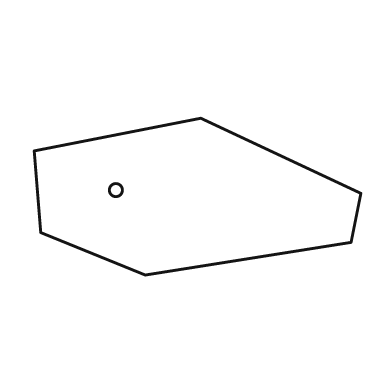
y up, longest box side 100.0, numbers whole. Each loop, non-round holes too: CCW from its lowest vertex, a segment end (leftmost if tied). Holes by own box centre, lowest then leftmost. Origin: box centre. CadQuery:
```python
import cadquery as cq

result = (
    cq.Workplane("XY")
    .moveTo(-16.0, -24.0)
    .lineTo(47.0, -14.0)
    .lineTo(50.0, 1.0)
    .lineTo(1.0, 24.0)
    .lineTo(-50.0, 14.0)
    .lineTo(-48.0, -11.0)
    .close()
    .moveTo(-25.0, 2.0)
    .circle(2.0)
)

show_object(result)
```